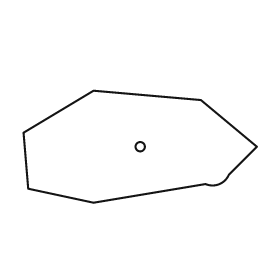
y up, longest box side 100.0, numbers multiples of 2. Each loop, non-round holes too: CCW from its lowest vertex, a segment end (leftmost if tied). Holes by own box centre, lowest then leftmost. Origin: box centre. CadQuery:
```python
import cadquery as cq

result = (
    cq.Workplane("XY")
    .moveTo(-20.0, -24.0)
    .lineTo(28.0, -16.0)
    .threePointArc((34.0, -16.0), (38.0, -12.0))
    .lineTo(50.0, 0.0)
    .lineTo(26.0, 20.0)
    .lineTo(-20.0, 24.0)
    .lineTo(-50.0, 6.0)
    .lineTo(-48.0, -18.0)
    .close()
    .moveTo(0.0, 0.0)
    .circle(2.0)
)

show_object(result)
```